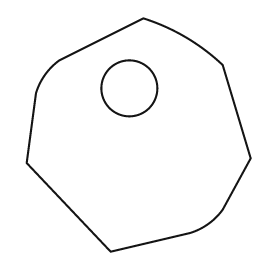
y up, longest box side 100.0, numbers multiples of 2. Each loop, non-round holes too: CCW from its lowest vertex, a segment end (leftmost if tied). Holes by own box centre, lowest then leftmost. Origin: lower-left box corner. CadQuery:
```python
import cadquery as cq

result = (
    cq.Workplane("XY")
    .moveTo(36.0, 0.0)
    .lineTo(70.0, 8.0)
    .threePointArc((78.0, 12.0), (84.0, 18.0))
    .lineTo(96.0, 40.0)
    .lineTo(84.0, 80.0)
    .threePointArc((68.0, 92.0), (50.0, 100.0))
    .lineTo(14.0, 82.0)
    .threePointArc((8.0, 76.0), (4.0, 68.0))
    .lineTo(0.0, 38.0)
    .close()
    .moveTo(44.0, 70.0)
    .circle(12.0)
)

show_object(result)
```